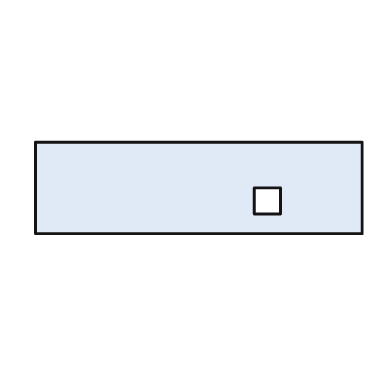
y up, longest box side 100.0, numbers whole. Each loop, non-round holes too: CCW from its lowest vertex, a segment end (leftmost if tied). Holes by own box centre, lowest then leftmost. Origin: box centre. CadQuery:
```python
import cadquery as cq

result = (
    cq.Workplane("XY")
    .moveTo(-50.0, -14.0)
    .lineTo(50.0, -14.0)
    .lineTo(50.0, 14.0)
    .lineTo(-50.0, 14.0)
    .close()
    .moveTo(17.0, -8.0)
    .lineTo(25.0, -8.0)
    .lineTo(25.0, 0.0)
    .lineTo(17.0, 0.0)
    .close()
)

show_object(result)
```